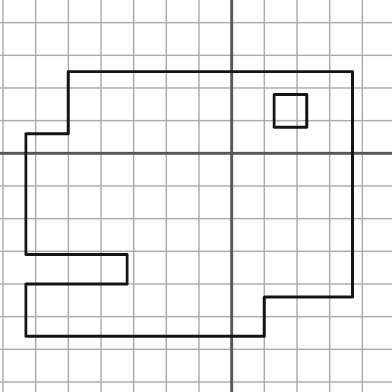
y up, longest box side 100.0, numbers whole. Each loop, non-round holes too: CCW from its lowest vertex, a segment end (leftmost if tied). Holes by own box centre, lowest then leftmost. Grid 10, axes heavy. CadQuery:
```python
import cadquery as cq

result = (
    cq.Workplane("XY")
    .moveTo(-63.0, -56.0)
    .lineTo(10.0, -56.0)
    .lineTo(10.0, -44.0)
    .lineTo(37.0, -44.0)
    .lineTo(37.0, 25.0)
    .lineTo(-50.0, 25.0)
    .lineTo(-50.0, 6.0)
    .lineTo(-63.0, 6.0)
    .lineTo(-63.0, -31.0)
    .lineTo(-32.0, -31.0)
    .lineTo(-32.0, -40.0)
    .lineTo(-63.0, -40.0)
    .close()
    .moveTo(13.0, 8.0)
    .lineTo(23.0, 8.0)
    .lineTo(23.0, 18.0)
    .lineTo(13.0, 18.0)
    .close()
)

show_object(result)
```